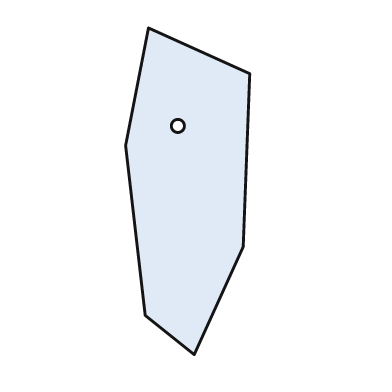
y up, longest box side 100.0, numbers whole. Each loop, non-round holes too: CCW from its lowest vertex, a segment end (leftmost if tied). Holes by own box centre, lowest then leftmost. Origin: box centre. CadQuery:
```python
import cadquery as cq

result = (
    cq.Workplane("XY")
    .moveTo(2.0, -50.0)
    .lineTo(17.0, -17.0)
    .lineTo(19.0, 36.0)
    .lineTo(-12.0, 50.0)
    .lineTo(-19.0, 14.0)
    .lineTo(-13.0, -38.0)
    .close()
    .moveTo(-3.0, 20.0)
    .circle(2.0)
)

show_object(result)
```